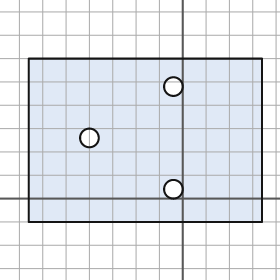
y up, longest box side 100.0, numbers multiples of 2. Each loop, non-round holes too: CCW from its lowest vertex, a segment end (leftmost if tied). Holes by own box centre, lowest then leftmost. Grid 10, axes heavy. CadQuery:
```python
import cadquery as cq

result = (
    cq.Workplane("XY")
    .moveTo(-66.0, -10.0)
    .lineTo(34.0, -10.0)
    .lineTo(34.0, 60.0)
    .lineTo(-66.0, 60.0)
    .close()
    .moveTo(-4.0, 4.0)
    .circle(4.0)
    .moveTo(-40.0, 26.0)
    .circle(4.0)
    .moveTo(-4.0, 48.0)
    .circle(4.0)
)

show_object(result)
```